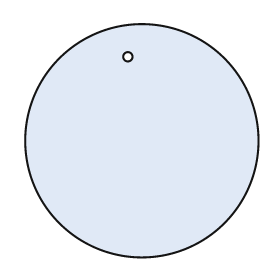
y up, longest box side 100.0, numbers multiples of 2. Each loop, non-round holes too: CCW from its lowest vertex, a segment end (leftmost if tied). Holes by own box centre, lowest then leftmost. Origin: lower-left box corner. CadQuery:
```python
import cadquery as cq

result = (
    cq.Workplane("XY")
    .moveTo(50.0, 50.0)
    .circle(50.0)
    .moveTo(44.0, 86.0)
    .circle(2.0)
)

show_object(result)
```